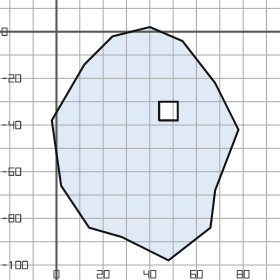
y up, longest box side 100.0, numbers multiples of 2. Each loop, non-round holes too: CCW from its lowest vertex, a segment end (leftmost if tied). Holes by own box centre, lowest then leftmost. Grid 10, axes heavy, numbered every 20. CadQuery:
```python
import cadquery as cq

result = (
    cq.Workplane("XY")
    .moveTo(48.0, -98.0)
    .lineTo(66.0, -84.0)
    .lineTo(68.0, -68.0)
    .lineTo(78.0, -42.0)
    .lineTo(68.0, -22.0)
    .lineTo(54.0, -4.0)
    .lineTo(40.0, 2.0)
    .lineTo(24.0, -2.0)
    .lineTo(12.0, -14.0)
    .lineTo(-2.0, -38.0)
    .lineTo(2.0, -66.0)
    .lineTo(14.0, -84.0)
    .lineTo(28.0, -88.0)
    .close()
    .moveTo(44.0, -38.0)
    .lineTo(52.0, -38.0)
    .lineTo(52.0, -30.0)
    .lineTo(44.0, -30.0)
    .close()
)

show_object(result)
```